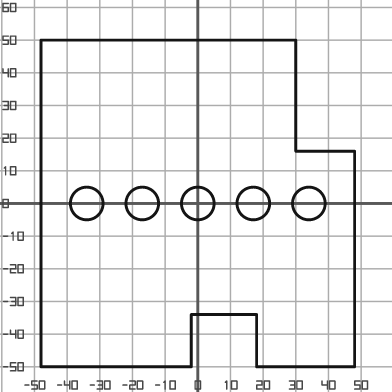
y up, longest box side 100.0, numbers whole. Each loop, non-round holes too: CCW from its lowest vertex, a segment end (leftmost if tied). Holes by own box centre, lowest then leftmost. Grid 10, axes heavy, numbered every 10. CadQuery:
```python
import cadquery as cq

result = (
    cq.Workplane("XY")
    .moveTo(-48.0, -50.0)
    .lineTo(-2.0, -50.0)
    .lineTo(-2.0, -34.0)
    .lineTo(18.0, -34.0)
    .lineTo(18.0, -50.0)
    .lineTo(48.0, -50.0)
    .lineTo(48.0, 16.0)
    .lineTo(30.0, 16.0)
    .lineTo(30.0, 50.0)
    .lineTo(-48.0, 50.0)
    .close()
    .moveTo(-34.0, 0.0)
    .circle(5.0)
    .moveTo(-17.0, 0.0)
    .circle(5.0)
    .moveTo(0.0, 0.0)
    .circle(5.0)
    .moveTo(17.0, 0.0)
    .circle(5.0)
    .moveTo(34.0, 0.0)
    .circle(5.0)
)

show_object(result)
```